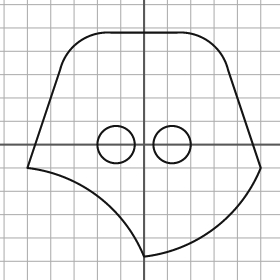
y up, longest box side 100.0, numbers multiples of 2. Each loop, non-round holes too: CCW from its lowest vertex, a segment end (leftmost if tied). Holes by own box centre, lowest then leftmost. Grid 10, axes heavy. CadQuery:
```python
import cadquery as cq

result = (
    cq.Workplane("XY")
    .moveTo(0.0, -48.0)
    .threePointArc((30.0, -36.0), (50.0, -10.0))
    .lineTo(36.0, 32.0)
    .threePointArc((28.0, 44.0), (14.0, 48.0))
    .lineTo(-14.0, 48.0)
    .threePointArc((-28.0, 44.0), (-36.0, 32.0))
    .lineTo(-50.0, -10.0)
    .threePointArc((-20.0, -22.0), (0.0, -48.0))
    .close()
    .moveTo(-12.0, 0.0)
    .circle(8.0)
    .moveTo(12.0, 0.0)
    .circle(8.0)
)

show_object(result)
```